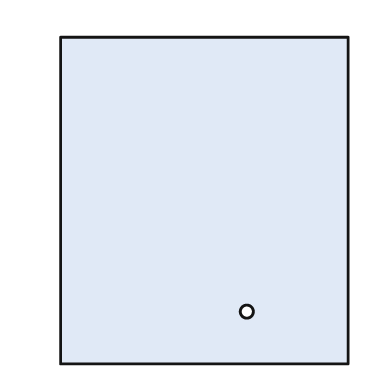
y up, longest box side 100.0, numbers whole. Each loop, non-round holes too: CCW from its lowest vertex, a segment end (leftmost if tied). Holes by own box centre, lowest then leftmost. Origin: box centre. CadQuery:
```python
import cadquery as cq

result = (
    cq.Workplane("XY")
    .moveTo(-44.0, -50.0)
    .lineTo(44.0, -50.0)
    .lineTo(44.0, 50.0)
    .lineTo(-44.0, 50.0)
    .close()
    .moveTo(13.0, -34.0)
    .circle(2.0)
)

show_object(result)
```